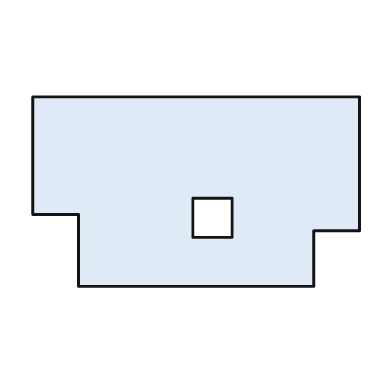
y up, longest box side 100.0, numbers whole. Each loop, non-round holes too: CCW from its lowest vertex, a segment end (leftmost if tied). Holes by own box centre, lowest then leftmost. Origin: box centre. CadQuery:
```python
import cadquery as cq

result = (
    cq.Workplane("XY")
    .moveTo(-36.0, -29.0)
    .lineTo(36.0, -29.0)
    .lineTo(36.0, -12.0)
    .lineTo(50.0, -12.0)
    .lineTo(50.0, 29.0)
    .lineTo(-50.0, 29.0)
    .lineTo(-50.0, -7.0)
    .lineTo(-36.0, -7.0)
    .close()
    .moveTo(-1.0, -14.0)
    .lineTo(11.0, -14.0)
    .lineTo(11.0, -2.0)
    .lineTo(-1.0, -2.0)
    .close()
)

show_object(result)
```